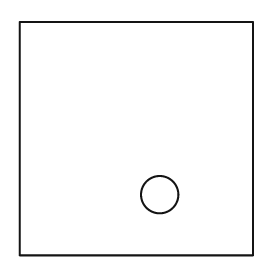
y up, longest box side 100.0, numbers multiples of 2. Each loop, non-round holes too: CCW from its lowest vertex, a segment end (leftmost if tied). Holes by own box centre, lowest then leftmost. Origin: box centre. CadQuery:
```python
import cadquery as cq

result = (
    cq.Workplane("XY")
    .moveTo(-50.0, -50.0)
    .lineTo(50.0, -50.0)
    .lineTo(50.0, 50.0)
    .lineTo(-50.0, 50.0)
    .close()
    .moveTo(10.0, -24.0)
    .circle(8.0)
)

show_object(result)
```